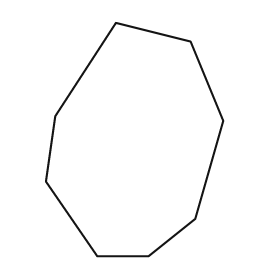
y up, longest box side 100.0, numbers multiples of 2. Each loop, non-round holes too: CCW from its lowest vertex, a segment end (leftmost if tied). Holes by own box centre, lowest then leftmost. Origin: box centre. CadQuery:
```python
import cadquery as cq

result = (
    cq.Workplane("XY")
    .moveTo(-16.0, -50.0)
    .lineTo(6.0, -50.0)
    .lineTo(26.0, -34.0)
    .lineTo(38.0, 8.0)
    .lineTo(24.0, 42.0)
    .lineTo(-8.0, 50.0)
    .lineTo(-34.0, 10.0)
    .lineTo(-38.0, -18.0)
    .close()
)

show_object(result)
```